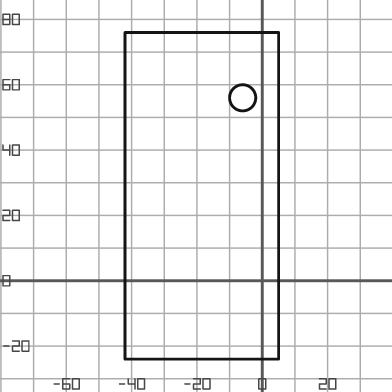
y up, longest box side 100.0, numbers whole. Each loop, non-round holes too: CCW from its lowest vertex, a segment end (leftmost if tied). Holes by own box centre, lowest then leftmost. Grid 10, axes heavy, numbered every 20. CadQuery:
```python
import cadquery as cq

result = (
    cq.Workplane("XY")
    .moveTo(-42.0, -24.0)
    .lineTo(5.0, -24.0)
    .lineTo(5.0, 76.0)
    .lineTo(-42.0, 76.0)
    .close()
    .moveTo(-6.0, 56.0)
    .circle(4.0)
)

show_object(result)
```